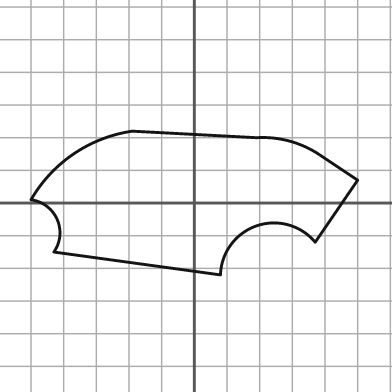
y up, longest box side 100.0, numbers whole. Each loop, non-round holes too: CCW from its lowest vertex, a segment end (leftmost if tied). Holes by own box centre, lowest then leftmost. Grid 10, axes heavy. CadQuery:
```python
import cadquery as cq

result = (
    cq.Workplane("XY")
    .moveTo(8.0, -22.0)
    .threePointArc((19.0, -7.0), (37.0, -12.0))
    .lineTo(50.0, 7.0)
    .lineTo(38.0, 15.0)
    .threePointArc((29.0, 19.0), (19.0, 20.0))
    .lineTo(-19.0, 22.0)
    .threePointArc((-37.0, 15.0), (-50.0, 1.0))
    .threePointArc((-42.0, -5.0), (-43.0, -15.0))
    .close()
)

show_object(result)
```